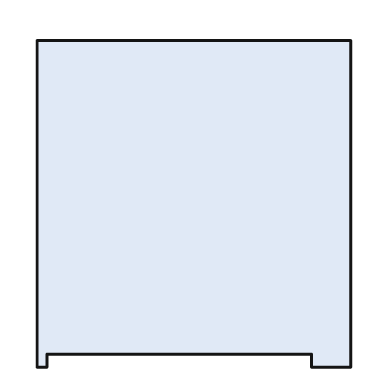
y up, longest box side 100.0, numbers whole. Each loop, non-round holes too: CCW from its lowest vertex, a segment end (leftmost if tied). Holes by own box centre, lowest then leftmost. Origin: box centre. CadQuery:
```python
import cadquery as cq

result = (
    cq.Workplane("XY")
    .moveTo(-48.0, -50.0)
    .lineTo(-45.0, -50.0)
    .lineTo(-45.0, -46.0)
    .lineTo(36.0, -46.0)
    .lineTo(36.0, -50.0)
    .lineTo(48.0, -50.0)
    .lineTo(48.0, 50.0)
    .lineTo(-48.0, 50.0)
    .close()
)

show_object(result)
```